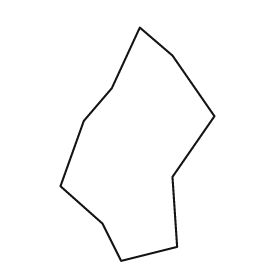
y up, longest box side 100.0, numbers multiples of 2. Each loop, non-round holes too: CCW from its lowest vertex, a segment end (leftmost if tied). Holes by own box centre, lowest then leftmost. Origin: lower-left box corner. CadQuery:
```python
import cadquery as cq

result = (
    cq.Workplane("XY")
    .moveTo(26.0, 0.0)
    .lineTo(50.0, 6.0)
    .lineTo(48.0, 36.0)
    .lineTo(66.0, 62.0)
    .lineTo(48.0, 88.0)
    .lineTo(34.0, 100.0)
    .lineTo(22.0, 74.0)
    .lineTo(10.0, 60.0)
    .lineTo(0.0, 32.0)
    .lineTo(18.0, 16.0)
    .close()
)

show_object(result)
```